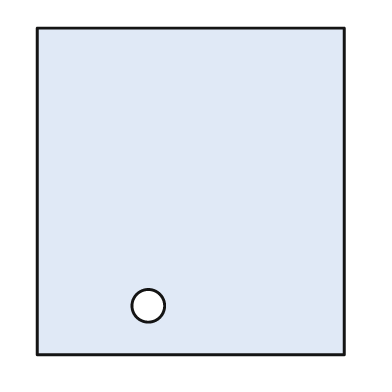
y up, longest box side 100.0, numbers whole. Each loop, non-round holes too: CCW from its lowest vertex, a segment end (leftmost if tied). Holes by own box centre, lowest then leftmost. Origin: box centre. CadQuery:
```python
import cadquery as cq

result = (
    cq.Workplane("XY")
    .moveTo(-47.0, -50.0)
    .lineTo(47.0, -50.0)
    .lineTo(47.0, 50.0)
    .lineTo(-47.0, 50.0)
    .close()
    .moveTo(-13.0, -35.0)
    .circle(5.0)
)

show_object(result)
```